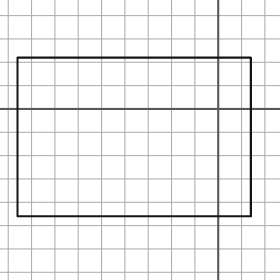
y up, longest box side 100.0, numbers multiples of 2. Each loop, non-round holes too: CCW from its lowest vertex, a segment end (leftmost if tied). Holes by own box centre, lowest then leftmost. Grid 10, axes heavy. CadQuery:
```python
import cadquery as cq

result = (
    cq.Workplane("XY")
    .moveTo(-86.0, -46.0)
    .lineTo(14.0, -46.0)
    .lineTo(14.0, 22.0)
    .lineTo(-86.0, 22.0)
    .close()
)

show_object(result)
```